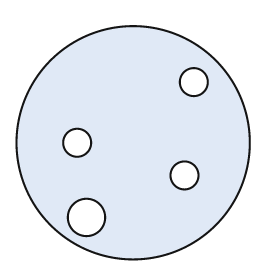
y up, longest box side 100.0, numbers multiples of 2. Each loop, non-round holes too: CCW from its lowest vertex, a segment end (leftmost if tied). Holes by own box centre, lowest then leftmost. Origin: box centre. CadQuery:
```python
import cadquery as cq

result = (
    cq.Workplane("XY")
    .moveTo(0.0, 0.0)
    .circle(50.0)
    .moveTo(-20.0, -32.0)
    .circle(8.0)
    .moveTo(22.0, -14.0)
    .circle(6.0)
    .moveTo(-24.0, 0.0)
    .circle(6.0)
    .moveTo(26.0, 26.0)
    .circle(6.0)
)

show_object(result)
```